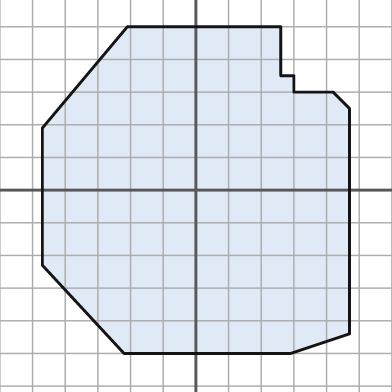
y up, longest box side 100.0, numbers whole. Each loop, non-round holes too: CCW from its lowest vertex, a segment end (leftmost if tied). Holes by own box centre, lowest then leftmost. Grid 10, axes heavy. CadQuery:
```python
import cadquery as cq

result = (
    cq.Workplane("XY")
    .moveTo(-22.0, -50.0)
    .lineTo(29.0, -50.0)
    .lineTo(47.0, -44.0)
    .lineTo(47.0, 25.0)
    .lineTo(42.0, 30.0)
    .lineTo(30.0, 30.0)
    .lineTo(30.0, 35.0)
    .lineTo(26.0, 35.0)
    .lineTo(26.0, 50.0)
    .lineTo(-21.0, 50.0)
    .lineTo(-47.0, 19.0)
    .lineTo(-47.0, -23.0)
    .close()
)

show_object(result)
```